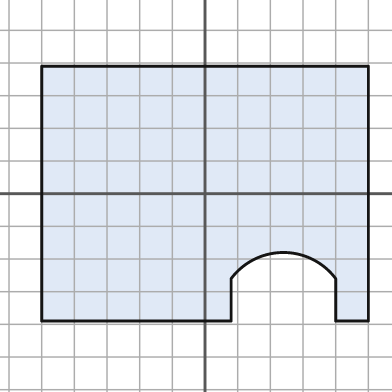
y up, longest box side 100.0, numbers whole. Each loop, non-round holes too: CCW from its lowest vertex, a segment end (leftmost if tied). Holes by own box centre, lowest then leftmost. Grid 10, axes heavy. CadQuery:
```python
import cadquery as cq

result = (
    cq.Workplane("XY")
    .moveTo(-50.0, -39.0)
    .lineTo(8.0, -39.0)
    .lineTo(8.0, -26.0)
    .threePointArc((24.0, -18.0), (40.0, -26.0))
    .lineTo(40.0, -39.0)
    .lineTo(50.0, -39.0)
    .lineTo(50.0, 39.0)
    .lineTo(-50.0, 39.0)
    .close()
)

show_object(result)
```